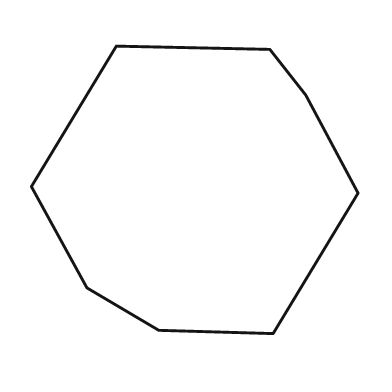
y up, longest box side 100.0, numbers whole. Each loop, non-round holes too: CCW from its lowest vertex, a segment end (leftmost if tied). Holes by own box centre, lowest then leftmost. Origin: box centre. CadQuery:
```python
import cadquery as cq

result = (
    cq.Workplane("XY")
    .moveTo(24.0, -44.0)
    .lineTo(50.0, -1.0)
    .lineTo(34.0, 29.0)
    .lineTo(23.0, 43.0)
    .lineTo(-24.0, 44.0)
    .lineTo(-50.0, 1.0)
    .lineTo(-33.0, -30.0)
    .lineTo(-11.0, -43.0)
    .close()
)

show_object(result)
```